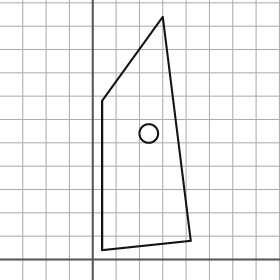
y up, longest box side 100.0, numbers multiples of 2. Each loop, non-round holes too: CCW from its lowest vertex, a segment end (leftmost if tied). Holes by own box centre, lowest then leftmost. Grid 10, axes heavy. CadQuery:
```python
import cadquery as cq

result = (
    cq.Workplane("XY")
    .moveTo(4.0, 4.0)
    .lineTo(42.0, 8.0)
    .lineTo(30.0, 104.0)
    .lineTo(4.0, 68.0)
    .close()
    .moveTo(24.0, 54.0)
    .circle(4.0)
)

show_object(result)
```